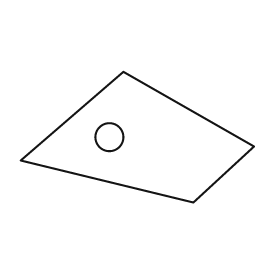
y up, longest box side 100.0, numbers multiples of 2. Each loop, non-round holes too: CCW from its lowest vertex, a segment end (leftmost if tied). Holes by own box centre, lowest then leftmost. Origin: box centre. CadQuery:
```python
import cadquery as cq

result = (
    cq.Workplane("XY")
    .moveTo(24.0, -28.0)
    .lineTo(50.0, -4.0)
    .lineTo(-6.0, 28.0)
    .lineTo(-50.0, -10.0)
    .close()
    .moveTo(-12.0, 0.0)
    .circle(6.0)
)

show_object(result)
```